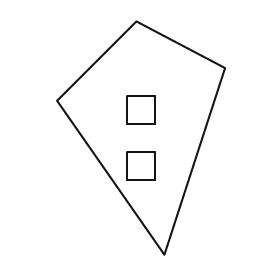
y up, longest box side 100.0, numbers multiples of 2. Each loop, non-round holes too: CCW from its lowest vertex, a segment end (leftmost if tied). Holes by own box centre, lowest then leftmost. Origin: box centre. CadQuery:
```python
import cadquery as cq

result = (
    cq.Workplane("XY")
    .moveTo(10.0, -50.0)
    .lineTo(36.0, 30.0)
    .lineTo(-2.0, 50.0)
    .lineTo(-36.0, 16.0)
    .close()
    .moveTo(-6.0, -18.0)
    .lineTo(6.0, -18.0)
    .lineTo(6.0, -6.0)
    .lineTo(-6.0, -6.0)
    .close()
    .moveTo(-6.0, 6.0)
    .lineTo(6.0, 6.0)
    .lineTo(6.0, 18.0)
    .lineTo(-6.0, 18.0)
    .close()
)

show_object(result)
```